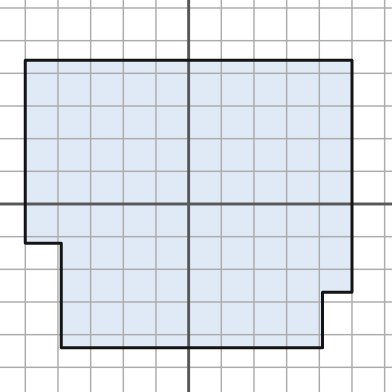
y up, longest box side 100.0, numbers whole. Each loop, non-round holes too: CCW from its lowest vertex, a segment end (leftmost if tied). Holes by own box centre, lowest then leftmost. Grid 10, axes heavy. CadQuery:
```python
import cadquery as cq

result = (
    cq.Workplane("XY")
    .moveTo(-39.0, -44.0)
    .lineTo(41.0, -44.0)
    .lineTo(41.0, -27.0)
    .lineTo(50.0, -27.0)
    .lineTo(50.0, 44.0)
    .lineTo(-50.0, 44.0)
    .lineTo(-50.0, -12.0)
    .lineTo(-39.0, -12.0)
    .close()
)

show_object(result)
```